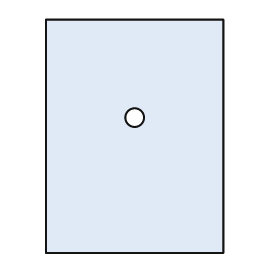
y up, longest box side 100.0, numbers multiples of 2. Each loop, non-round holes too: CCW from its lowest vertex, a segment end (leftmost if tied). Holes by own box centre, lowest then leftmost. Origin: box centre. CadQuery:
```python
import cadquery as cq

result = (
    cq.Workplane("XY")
    .moveTo(-38.0, -50.0)
    .lineTo(38.0, -50.0)
    .lineTo(38.0, 50.0)
    .lineTo(-38.0, 50.0)
    .close()
    .moveTo(0.0, 8.0)
    .circle(4.0)
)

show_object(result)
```